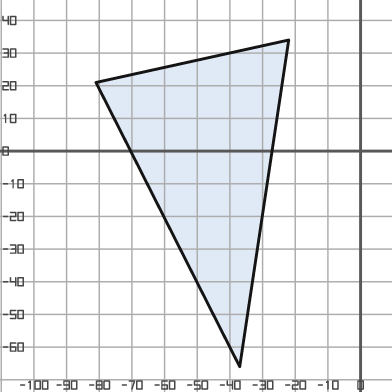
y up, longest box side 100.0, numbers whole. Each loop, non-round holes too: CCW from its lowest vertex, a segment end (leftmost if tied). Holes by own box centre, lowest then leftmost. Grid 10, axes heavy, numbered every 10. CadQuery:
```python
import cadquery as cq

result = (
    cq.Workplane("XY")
    .moveTo(-37.0, -66.0)
    .lineTo(-22.0, 34.0)
    .lineTo(-81.0, 21.0)
    .close()
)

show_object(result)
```